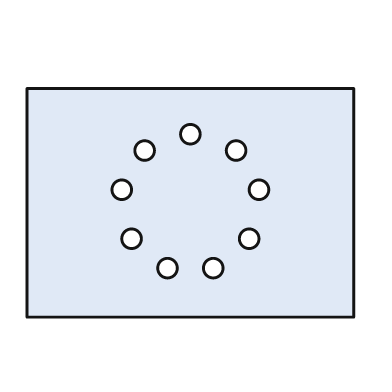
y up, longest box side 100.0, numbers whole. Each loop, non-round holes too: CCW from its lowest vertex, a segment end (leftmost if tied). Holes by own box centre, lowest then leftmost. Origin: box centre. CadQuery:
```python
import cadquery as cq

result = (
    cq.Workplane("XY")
    .moveTo(-50.0, -35.0)
    .lineTo(50.0, -35.0)
    .lineTo(50.0, 35.0)
    .lineTo(-50.0, 35.0)
    .close()
    .moveTo(-7.0, -20.0)
    .circle(3.0)
    .moveTo(7.0, -20.0)
    .circle(3.0)
    .moveTo(-18.0, -11.0)
    .circle(3.0)
    .moveTo(18.0, -11.0)
    .circle(3.0)
    .moveTo(-21.0, 4.0)
    .circle(3.0)
    .moveTo(21.0, 4.0)
    .circle(3.0)
    .moveTo(-14.0, 16.0)
    .circle(3.0)
    .moveTo(14.0, 16.0)
    .circle(3.0)
    .moveTo(0.0, 21.0)
    .circle(3.0)
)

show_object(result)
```